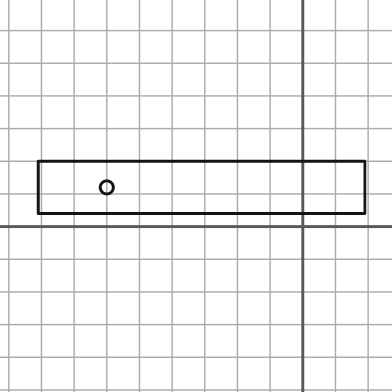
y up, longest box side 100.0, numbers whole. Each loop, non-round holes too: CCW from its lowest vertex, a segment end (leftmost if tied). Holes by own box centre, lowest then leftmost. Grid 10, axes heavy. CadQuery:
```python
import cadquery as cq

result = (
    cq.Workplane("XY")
    .moveTo(-81.0, 4.0)
    .lineTo(19.0, 4.0)
    .lineTo(19.0, 20.0)
    .lineTo(-81.0, 20.0)
    .close()
    .moveTo(-60.0, 12.0)
    .circle(2.0)
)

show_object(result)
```